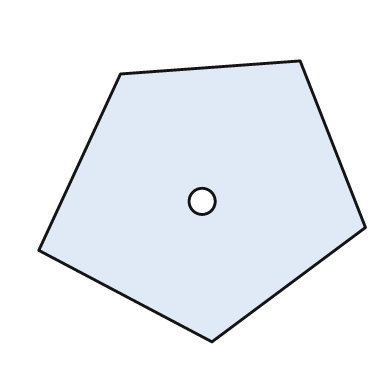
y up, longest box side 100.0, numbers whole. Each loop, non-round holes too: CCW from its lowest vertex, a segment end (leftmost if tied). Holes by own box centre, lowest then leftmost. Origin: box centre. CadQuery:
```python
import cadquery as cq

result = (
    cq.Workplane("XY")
    .moveTo(3.0, -43.0)
    .lineTo(50.0, -8.0)
    .lineTo(30.0, 43.0)
    .lineTo(-25.0, 39.0)
    .lineTo(-50.0, -15.0)
    .close()
    .moveTo(0.0, 0.0)
    .circle(4.0)
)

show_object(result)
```